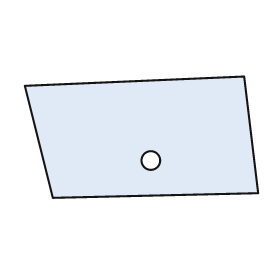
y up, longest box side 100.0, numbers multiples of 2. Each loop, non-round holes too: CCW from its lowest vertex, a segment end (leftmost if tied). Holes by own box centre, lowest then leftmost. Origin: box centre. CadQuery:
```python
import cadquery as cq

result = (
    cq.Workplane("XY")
    .moveTo(-38.0, -26.0)
    .lineTo(50.0, -24.0)
    .lineTo(44.0, 26.0)
    .lineTo(-50.0, 22.0)
    .close()
    .moveTo(4.0, -10.0)
    .circle(4.0)
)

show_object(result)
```